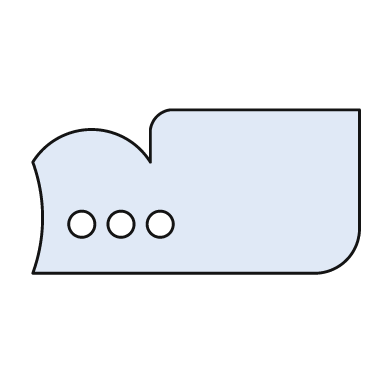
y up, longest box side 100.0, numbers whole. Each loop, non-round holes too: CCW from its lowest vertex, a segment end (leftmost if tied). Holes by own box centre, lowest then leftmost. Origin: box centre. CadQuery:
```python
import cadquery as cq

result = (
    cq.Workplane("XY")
    .moveTo(-50.0, -25.0)
    .lineTo(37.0, -25.0)
    .threePointArc((46.0, -21.0), (50.0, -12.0))
    .lineTo(50.0, 25.0)
    .lineTo(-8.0, 25.0)
    .threePointArc((-12.0, 23.0), (-14.0, 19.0))
    .lineTo(-14.0, 9.0)
    .threePointArc((-32.0, 19.0), (-50.0, 9.0))
    .threePointArc((-47.0, -8.0), (-50.0, -25.0))
    .close()
    .moveTo(-35.0, -10.0)
    .circle(4.0)
    .moveTo(-23.0, -10.0)
    .circle(4.0)
    .moveTo(-11.0, -10.0)
    .circle(4.0)
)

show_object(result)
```